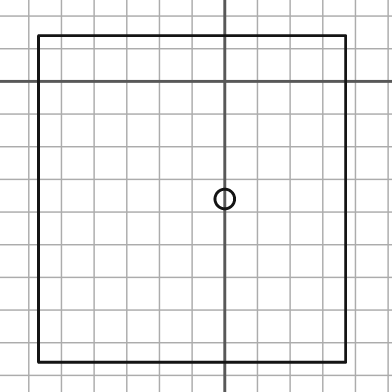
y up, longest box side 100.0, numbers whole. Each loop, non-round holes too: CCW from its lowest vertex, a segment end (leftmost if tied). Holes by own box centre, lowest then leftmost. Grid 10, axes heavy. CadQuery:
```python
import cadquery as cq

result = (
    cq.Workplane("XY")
    .moveTo(-57.0, -86.0)
    .lineTo(37.0, -86.0)
    .lineTo(37.0, 14.0)
    .lineTo(-57.0, 14.0)
    .close()
    .moveTo(0.0, -36.0)
    .circle(3.0)
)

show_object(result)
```